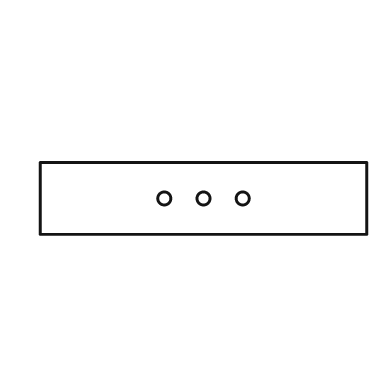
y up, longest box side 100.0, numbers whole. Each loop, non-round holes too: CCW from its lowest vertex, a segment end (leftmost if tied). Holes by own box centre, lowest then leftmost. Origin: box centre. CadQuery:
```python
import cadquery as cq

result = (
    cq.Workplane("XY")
    .moveTo(-50.0, -11.0)
    .lineTo(50.0, -11.0)
    .lineTo(50.0, 11.0)
    .lineTo(-50.0, 11.0)
    .close()
    .moveTo(-12.0, 0.0)
    .circle(2.0)
    .moveTo(0.0, 0.0)
    .circle(2.0)
    .moveTo(12.0, 0.0)
    .circle(2.0)
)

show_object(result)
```